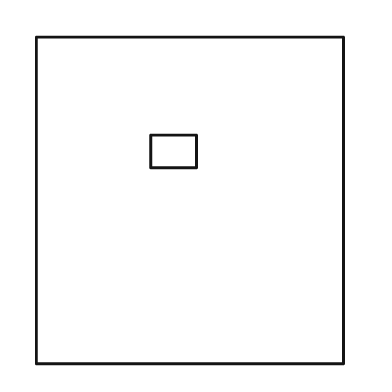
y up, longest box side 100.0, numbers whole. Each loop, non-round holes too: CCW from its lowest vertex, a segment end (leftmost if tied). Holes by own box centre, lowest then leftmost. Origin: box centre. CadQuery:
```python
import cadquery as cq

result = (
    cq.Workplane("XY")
    .moveTo(-47.0, -50.0)
    .lineTo(47.0, -50.0)
    .lineTo(47.0, 50.0)
    .lineTo(-47.0, 50.0)
    .close()
    .moveTo(-12.0, 10.0)
    .lineTo(2.0, 10.0)
    .lineTo(2.0, 20.0)
    .lineTo(-12.0, 20.0)
    .close()
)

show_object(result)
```